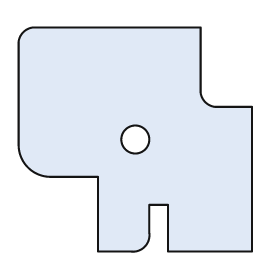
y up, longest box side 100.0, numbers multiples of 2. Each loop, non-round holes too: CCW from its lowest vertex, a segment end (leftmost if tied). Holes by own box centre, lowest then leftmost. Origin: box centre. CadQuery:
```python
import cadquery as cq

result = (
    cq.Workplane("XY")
    .moveTo(-16.0, -48.0)
    .lineTo(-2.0, -48.0)
    .threePointArc((4.0, -46.0), (6.0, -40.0))
    .lineTo(6.0, -28.0)
    .lineTo(14.0, -28.0)
    .lineTo(14.0, -48.0)
    .lineTo(50.0, -48.0)
    .lineTo(50.0, 14.0)
    .lineTo(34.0, 14.0)
    .threePointArc((30.0, 16.0), (28.0, 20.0))
    .lineTo(28.0, 48.0)
    .lineTo(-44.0, 48.0)
    .threePointArc((-48.0, 46.0), (-50.0, 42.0))
    .lineTo(-50.0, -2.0)
    .threePointArc((-46.0, -12.0), (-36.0, -16.0))
    .lineTo(-16.0, -16.0)
    .close()
    .moveTo(0.0, 0.0)
    .circle(6.0)
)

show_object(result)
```